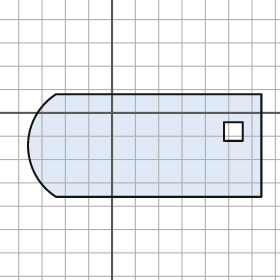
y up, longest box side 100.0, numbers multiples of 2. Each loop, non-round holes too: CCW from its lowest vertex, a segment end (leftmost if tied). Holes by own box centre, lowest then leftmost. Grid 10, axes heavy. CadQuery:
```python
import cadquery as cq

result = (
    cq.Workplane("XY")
    .moveTo(-24.0, -36.0)
    .lineTo(64.0, -36.0)
    .lineTo(64.0, 8.0)
    .lineTo(-24.0, 8.0)
    .threePointArc((-36.0, -14.0), (-24.0, -36.0))
    .close()
    .moveTo(48.0, -12.0)
    .lineTo(56.0, -12.0)
    .lineTo(56.0, -4.0)
    .lineTo(48.0, -4.0)
    .close()
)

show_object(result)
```